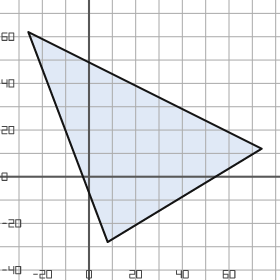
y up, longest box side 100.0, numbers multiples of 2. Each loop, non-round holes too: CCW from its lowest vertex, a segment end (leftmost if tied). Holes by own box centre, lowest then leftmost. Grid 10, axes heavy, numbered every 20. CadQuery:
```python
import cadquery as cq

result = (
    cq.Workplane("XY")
    .moveTo(8.0, -28.0)
    .lineTo(74.0, 12.0)
    .lineTo(-26.0, 62.0)
    .close()
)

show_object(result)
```